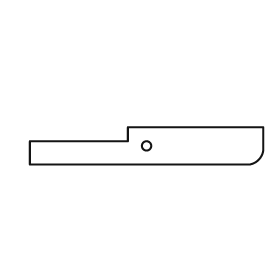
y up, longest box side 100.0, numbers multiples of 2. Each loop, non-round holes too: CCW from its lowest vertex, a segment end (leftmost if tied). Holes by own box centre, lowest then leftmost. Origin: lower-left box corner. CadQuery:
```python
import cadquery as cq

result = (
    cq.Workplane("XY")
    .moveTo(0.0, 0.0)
    .lineTo(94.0, 0.0)
    .threePointArc((98.0, 2.0), (100.0, 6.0))
    .lineTo(100.0, 16.0)
    .lineTo(42.0, 16.0)
    .lineTo(42.0, 10.0)
    .lineTo(0.0, 10.0)
    .close()
    .moveTo(50.0, 8.0)
    .circle(2.0)
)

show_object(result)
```